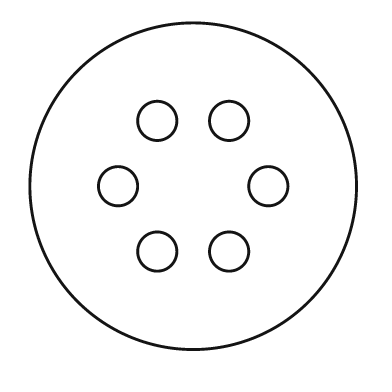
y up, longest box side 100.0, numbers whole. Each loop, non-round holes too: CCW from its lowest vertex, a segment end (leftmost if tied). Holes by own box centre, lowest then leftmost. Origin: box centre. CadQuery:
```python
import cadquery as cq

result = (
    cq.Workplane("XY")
    .moveTo(0.0, 0.0)
    .circle(50.0)
    .moveTo(-11.0, -20.0)
    .circle(6.0)
    .moveTo(11.0, -20.0)
    .circle(6.0)
    .moveTo(-23.0, 0.0)
    .circle(6.0)
    .moveTo(23.0, 0.0)
    .circle(6.0)
    .moveTo(-11.0, 20.0)
    .circle(6.0)
    .moveTo(11.0, 20.0)
    .circle(6.0)
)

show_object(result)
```